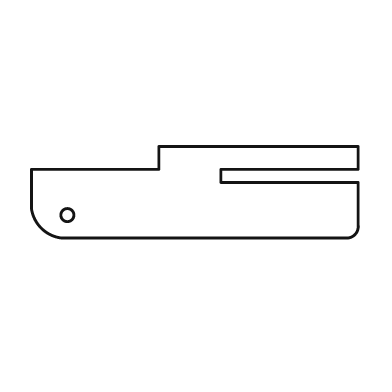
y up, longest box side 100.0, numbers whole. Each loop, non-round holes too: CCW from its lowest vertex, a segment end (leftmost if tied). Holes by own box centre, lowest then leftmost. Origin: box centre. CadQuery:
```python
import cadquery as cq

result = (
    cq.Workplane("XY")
    .moveTo(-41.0, -14.0)
    .lineTo(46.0, -14.0)
    .threePointArc((49.0, -13.0), (50.0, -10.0))
    .lineTo(50.0, 3.0)
    .lineTo(8.0, 3.0)
    .lineTo(8.0, 7.0)
    .lineTo(50.0, 7.0)
    .lineTo(50.0, 14.0)
    .lineTo(-11.0, 14.0)
    .lineTo(-11.0, 7.0)
    .lineTo(-50.0, 7.0)
    .lineTo(-50.0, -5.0)
    .threePointArc((-47.0, -11.0), (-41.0, -14.0))
    .close()
    .moveTo(-39.0, -7.0)
    .circle(2.0)
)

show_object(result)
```